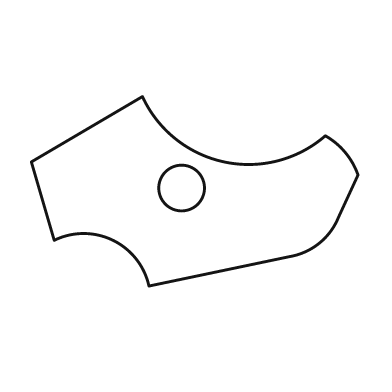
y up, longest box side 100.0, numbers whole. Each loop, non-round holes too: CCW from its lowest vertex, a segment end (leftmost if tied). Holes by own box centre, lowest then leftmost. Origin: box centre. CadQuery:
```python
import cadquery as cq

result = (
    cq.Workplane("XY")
    .moveTo(-14.0, -29.0)
    .lineTo(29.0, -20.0)
    .threePointArc((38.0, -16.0), (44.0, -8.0))
    .lineTo(50.0, 5.0)
    .threePointArc((46.0, 12.0), (40.0, 17.0))
    .threePointArc((9.0, 9.0), (-16.0, 29.0))
    .lineTo(-50.0, 9.0)
    .lineTo(-43.0, -15.0)
    .threePointArc((-25.0, -15.0), (-14.0, -29.0))
    .close()
    .moveTo(-4.0, 1.0)
    .circle(7.0)
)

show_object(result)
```